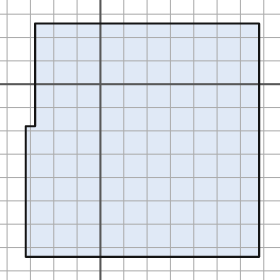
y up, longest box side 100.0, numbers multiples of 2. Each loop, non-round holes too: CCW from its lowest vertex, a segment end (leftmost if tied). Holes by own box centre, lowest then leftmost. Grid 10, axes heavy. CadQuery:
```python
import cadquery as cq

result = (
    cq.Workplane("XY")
    .moveTo(-32.0, -74.0)
    .lineTo(68.0, -74.0)
    .lineTo(68.0, 26.0)
    .lineTo(-28.0, 26.0)
    .lineTo(-28.0, -18.0)
    .lineTo(-32.0, -18.0)
    .close()
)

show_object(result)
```